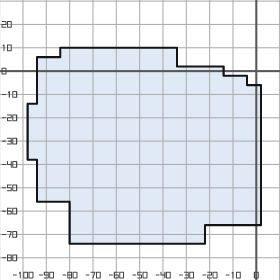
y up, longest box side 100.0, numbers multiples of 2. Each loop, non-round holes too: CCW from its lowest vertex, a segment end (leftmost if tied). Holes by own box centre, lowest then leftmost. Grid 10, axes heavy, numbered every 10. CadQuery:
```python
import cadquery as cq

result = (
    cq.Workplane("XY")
    .moveTo(-80.0, -74.0)
    .lineTo(-22.0, -74.0)
    .lineTo(-22.0, -66.0)
    .lineTo(2.0, -66.0)
    .lineTo(2.0, -6.0)
    .lineTo(-4.0, -6.0)
    .lineTo(-4.0, -2.0)
    .lineTo(-14.0, -2.0)
    .lineTo(-14.0, 2.0)
    .lineTo(-34.0, 2.0)
    .lineTo(-34.0, 10.0)
    .lineTo(-84.0, 10.0)
    .lineTo(-84.0, 6.0)
    .lineTo(-94.0, 6.0)
    .lineTo(-94.0, -14.0)
    .lineTo(-98.0, -14.0)
    .lineTo(-98.0, -38.0)
    .lineTo(-94.0, -38.0)
    .lineTo(-94.0, -56.0)
    .lineTo(-80.0, -56.0)
    .close()
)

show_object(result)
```